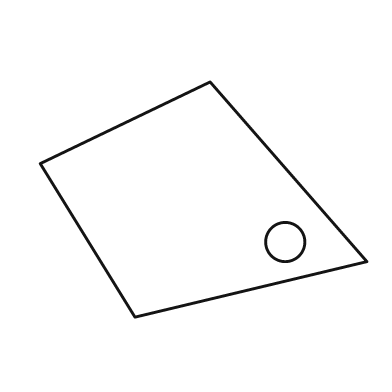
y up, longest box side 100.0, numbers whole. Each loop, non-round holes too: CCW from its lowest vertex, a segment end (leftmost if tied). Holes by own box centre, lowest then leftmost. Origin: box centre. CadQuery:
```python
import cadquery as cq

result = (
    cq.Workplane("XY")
    .moveTo(-21.0, -36.0)
    .lineTo(50.0, -19.0)
    .lineTo(2.0, 36.0)
    .lineTo(-50.0, 11.0)
    .close()
    .moveTo(25.0, -13.0)
    .circle(6.0)
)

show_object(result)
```